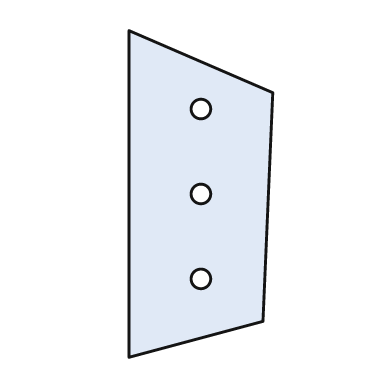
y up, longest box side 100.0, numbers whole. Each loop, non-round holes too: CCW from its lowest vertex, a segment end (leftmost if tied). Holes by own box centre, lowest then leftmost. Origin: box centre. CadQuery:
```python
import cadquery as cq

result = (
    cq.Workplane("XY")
    .moveTo(-22.0, -50.0)
    .lineTo(19.0, -39.0)
    .lineTo(22.0, 31.0)
    .lineTo(-22.0, 50.0)
    .close()
    .moveTo(0.0, -26.0)
    .circle(3.0)
    .moveTo(0.0, 0.0)
    .circle(3.0)
    .moveTo(0.0, 26.0)
    .circle(3.0)
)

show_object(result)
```